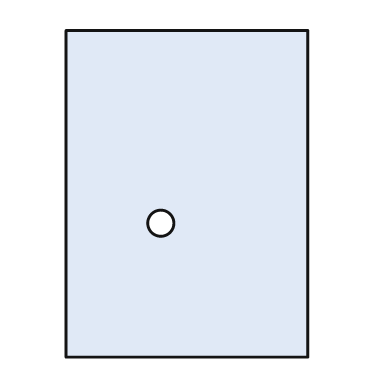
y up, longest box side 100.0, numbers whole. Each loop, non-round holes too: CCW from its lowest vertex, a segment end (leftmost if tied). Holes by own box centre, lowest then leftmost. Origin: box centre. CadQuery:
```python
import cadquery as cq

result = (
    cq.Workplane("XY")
    .moveTo(-37.0, -50.0)
    .lineTo(37.0, -50.0)
    .lineTo(37.0, 50.0)
    .lineTo(-37.0, 50.0)
    .close()
    .moveTo(-8.0, -9.0)
    .circle(4.0)
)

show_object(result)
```